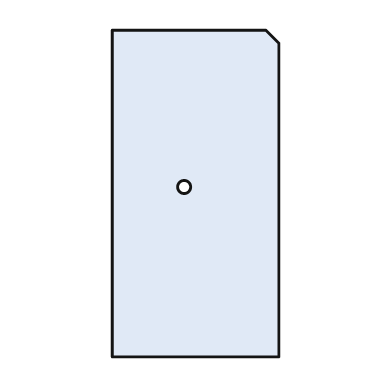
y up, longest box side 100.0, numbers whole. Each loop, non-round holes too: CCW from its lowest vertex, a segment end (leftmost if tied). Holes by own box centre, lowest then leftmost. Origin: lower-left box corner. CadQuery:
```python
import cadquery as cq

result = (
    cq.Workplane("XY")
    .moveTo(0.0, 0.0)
    .lineTo(51.0, 0.0)
    .lineTo(51.0, 96.0)
    .lineTo(47.0, 100.0)
    .lineTo(0.0, 100.0)
    .close()
    .moveTo(22.0, 52.0)
    .circle(2.0)
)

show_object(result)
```